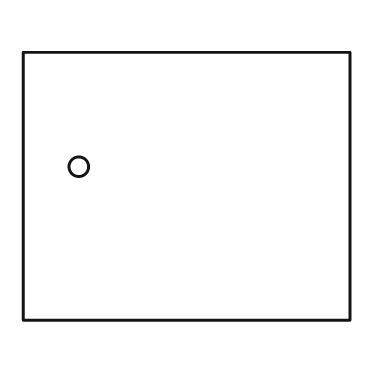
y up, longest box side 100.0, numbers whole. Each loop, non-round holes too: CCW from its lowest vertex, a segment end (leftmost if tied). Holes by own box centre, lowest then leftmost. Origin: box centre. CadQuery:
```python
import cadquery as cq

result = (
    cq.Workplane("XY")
    .moveTo(-50.0, -41.0)
    .lineTo(50.0, -41.0)
    .lineTo(50.0, 41.0)
    .lineTo(-50.0, 41.0)
    .close()
    .moveTo(-33.0, 6.0)
    .circle(3.0)
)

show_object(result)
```